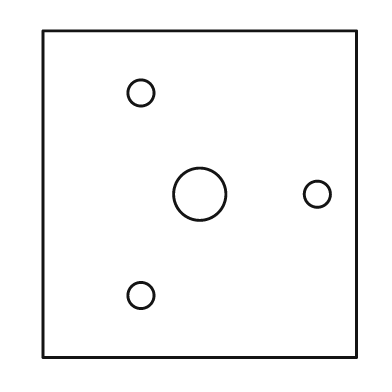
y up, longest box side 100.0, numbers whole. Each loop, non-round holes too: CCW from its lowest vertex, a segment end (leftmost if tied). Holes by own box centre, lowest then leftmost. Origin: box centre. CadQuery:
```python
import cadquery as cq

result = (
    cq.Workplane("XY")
    .moveTo(-48.0, -50.0)
    .lineTo(48.0, -50.0)
    .lineTo(48.0, 50.0)
    .lineTo(-48.0, 50.0)
    .close()
    .moveTo(-18.0, -31.0)
    .circle(4.0)
    .moveTo(0.0, 0.0)
    .circle(8.0)
    .moveTo(36.0, 0.0)
    .circle(4.0)
    .moveTo(-18.0, 31.0)
    .circle(4.0)
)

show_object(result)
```